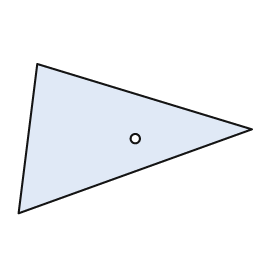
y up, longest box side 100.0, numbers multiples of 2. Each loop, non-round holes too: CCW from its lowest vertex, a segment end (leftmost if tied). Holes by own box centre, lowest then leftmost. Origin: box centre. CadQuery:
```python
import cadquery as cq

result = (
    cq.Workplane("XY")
    .moveTo(-50.0, -32.0)
    .lineTo(50.0, 4.0)
    .lineTo(-42.0, 32.0)
    .close()
    .moveTo(0.0, 0.0)
    .circle(2.0)
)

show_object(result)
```